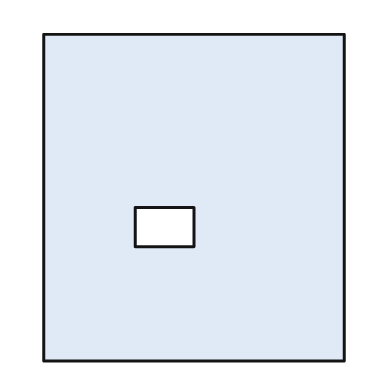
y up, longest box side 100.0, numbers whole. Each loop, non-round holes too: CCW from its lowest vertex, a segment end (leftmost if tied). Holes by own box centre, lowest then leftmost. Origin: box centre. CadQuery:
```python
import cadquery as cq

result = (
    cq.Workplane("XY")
    .moveTo(-46.0, -50.0)
    .lineTo(46.0, -50.0)
    .lineTo(46.0, 50.0)
    .lineTo(-46.0, 50.0)
    .close()
    .moveTo(-18.0, -15.0)
    .lineTo(0.0, -15.0)
    .lineTo(0.0, -3.0)
    .lineTo(-18.0, -3.0)
    .close()
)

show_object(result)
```